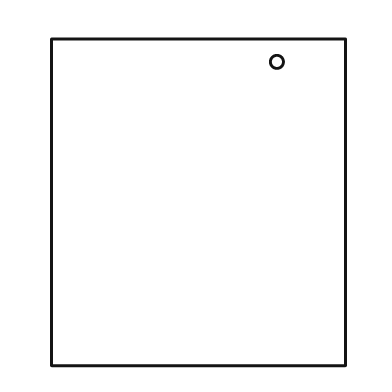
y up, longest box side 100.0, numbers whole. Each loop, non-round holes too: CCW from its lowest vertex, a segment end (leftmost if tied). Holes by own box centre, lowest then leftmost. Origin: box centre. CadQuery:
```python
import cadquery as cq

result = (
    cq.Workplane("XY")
    .moveTo(-45.0, -50.0)
    .lineTo(45.0, -50.0)
    .lineTo(45.0, 50.0)
    .lineTo(-45.0, 50.0)
    .close()
    .moveTo(24.0, 43.0)
    .circle(2.0)
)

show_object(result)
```